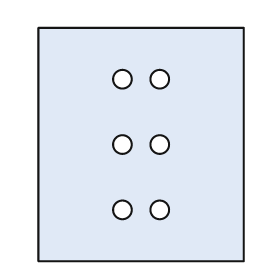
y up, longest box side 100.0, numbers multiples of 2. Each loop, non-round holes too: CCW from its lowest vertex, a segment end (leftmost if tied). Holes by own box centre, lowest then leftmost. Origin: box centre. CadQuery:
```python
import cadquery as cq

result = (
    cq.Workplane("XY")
    .moveTo(-44.0, -50.0)
    .lineTo(44.0, -50.0)
    .lineTo(44.0, 50.0)
    .lineTo(-44.0, 50.0)
    .close()
    .moveTo(-8.0, -28.0)
    .circle(4.0)
    .moveTo(8.0, -28.0)
    .circle(4.0)
    .moveTo(-8.0, 0.0)
    .circle(4.0)
    .moveTo(8.0, 0.0)
    .circle(4.0)
    .moveTo(-8.0, 28.0)
    .circle(4.0)
    .moveTo(8.0, 28.0)
    .circle(4.0)
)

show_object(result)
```